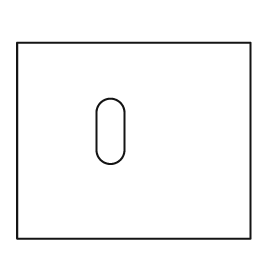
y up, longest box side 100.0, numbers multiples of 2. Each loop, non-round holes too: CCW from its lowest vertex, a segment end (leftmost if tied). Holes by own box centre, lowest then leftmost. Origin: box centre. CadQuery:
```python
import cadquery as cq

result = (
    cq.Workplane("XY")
    .moveTo(-50.0, -42.0)
    .lineTo(50.0, -42.0)
    .lineTo(50.0, 42.0)
    .lineTo(-50.0, 42.0)
    .close()
    .moveTo(-16.0, -4.0)
    .threePointArc((-10.0, -10.0), (-4.0, -4.0))
    .lineTo(-4.0, 12.0)
    .threePointArc((-10.0, 18.0), (-16.0, 12.0))
    .close()
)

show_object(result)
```